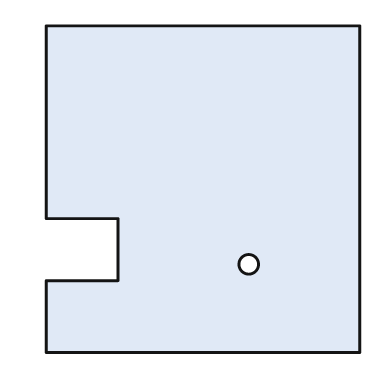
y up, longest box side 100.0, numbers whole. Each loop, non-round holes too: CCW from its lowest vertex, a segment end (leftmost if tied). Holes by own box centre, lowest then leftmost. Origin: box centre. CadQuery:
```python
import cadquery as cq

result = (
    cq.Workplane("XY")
    .moveTo(-48.0, -50.0)
    .lineTo(48.0, -50.0)
    .lineTo(48.0, 50.0)
    .lineTo(-48.0, 50.0)
    .lineTo(-48.0, -9.0)
    .lineTo(-26.0, -9.0)
    .lineTo(-26.0, -28.0)
    .lineTo(-48.0, -28.0)
    .close()
    .moveTo(14.0, -23.0)
    .circle(3.0)
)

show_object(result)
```